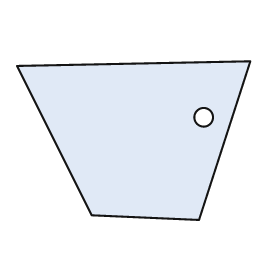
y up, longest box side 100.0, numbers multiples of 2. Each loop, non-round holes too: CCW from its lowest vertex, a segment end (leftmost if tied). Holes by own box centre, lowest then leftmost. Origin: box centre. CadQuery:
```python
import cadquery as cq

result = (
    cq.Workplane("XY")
    .moveTo(28.0, -34.0)
    .lineTo(50.0, 34.0)
    .lineTo(-50.0, 32.0)
    .lineTo(-18.0, -32.0)
    .close()
    .moveTo(30.0, 10.0)
    .circle(4.0)
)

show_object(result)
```